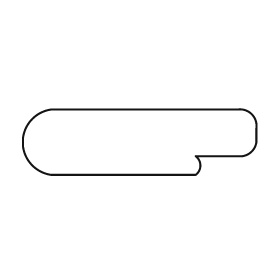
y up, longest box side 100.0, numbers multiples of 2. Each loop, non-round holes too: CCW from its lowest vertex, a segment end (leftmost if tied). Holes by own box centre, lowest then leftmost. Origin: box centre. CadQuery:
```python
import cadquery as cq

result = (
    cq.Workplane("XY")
    .moveTo(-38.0, -14.0)
    .lineTo(24.0, -14.0)
    .threePointArc((26.0, -10.0), (24.0, -6.0))
    .lineTo(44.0, -6.0)
    .threePointArc((48.0, -4.0), (50.0, 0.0))
    .lineTo(50.0, 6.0)
    .threePointArc((48.0, 12.0), (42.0, 14.0))
    .lineTo(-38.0, 14.0)
    .threePointArc((-46.0, 10.0), (-50.0, 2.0))
    .lineTo(-50.0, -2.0)
    .threePointArc((-46.0, -10.0), (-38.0, -14.0))
    .close()
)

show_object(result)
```